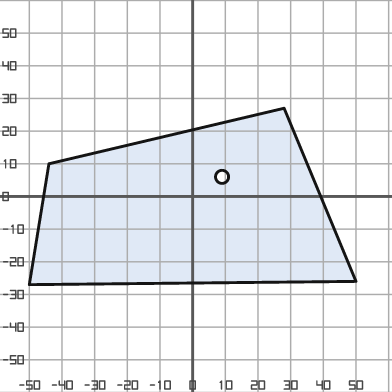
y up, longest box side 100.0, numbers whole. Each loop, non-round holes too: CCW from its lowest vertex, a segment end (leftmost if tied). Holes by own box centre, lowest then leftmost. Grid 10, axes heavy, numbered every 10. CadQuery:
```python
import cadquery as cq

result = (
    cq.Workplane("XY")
    .moveTo(-50.0, -27.0)
    .lineTo(50.0, -26.0)
    .lineTo(28.0, 27.0)
    .lineTo(-44.0, 10.0)
    .close()
    .moveTo(9.0, 6.0)
    .circle(2.0)
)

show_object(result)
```